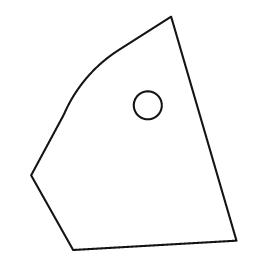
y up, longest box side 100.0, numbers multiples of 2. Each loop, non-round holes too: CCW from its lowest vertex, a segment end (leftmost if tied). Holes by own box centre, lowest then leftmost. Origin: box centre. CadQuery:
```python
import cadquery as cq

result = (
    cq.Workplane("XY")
    .moveTo(-26.0, -50.0)
    .lineTo(44.0, -46.0)
    .lineTo(16.0, 50.0)
    .lineTo(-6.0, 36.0)
    .threePointArc((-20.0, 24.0), (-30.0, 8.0))
    .lineTo(-44.0, -18.0)
    .close()
    .moveTo(6.0, 12.0)
    .circle(6.0)
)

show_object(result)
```